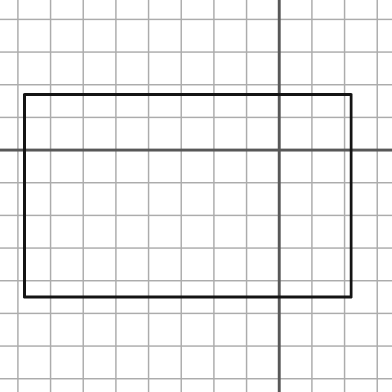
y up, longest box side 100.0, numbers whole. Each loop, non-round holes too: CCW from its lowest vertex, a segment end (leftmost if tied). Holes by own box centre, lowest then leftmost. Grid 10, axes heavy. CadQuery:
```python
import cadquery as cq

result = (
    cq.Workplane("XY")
    .moveTo(-78.0, -45.0)
    .lineTo(22.0, -45.0)
    .lineTo(22.0, 17.0)
    .lineTo(-78.0, 17.0)
    .close()
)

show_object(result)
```